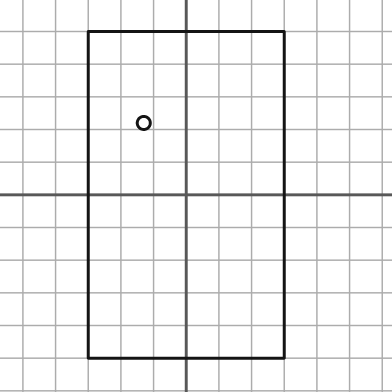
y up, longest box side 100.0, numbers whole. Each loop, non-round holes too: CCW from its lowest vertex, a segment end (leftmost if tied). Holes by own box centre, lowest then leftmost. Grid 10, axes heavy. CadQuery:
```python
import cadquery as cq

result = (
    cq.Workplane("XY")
    .moveTo(-30.0, -50.0)
    .lineTo(30.0, -50.0)
    .lineTo(30.0, 50.0)
    .lineTo(-30.0, 50.0)
    .close()
    .moveTo(-13.0, 22.0)
    .circle(2.0)
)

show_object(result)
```